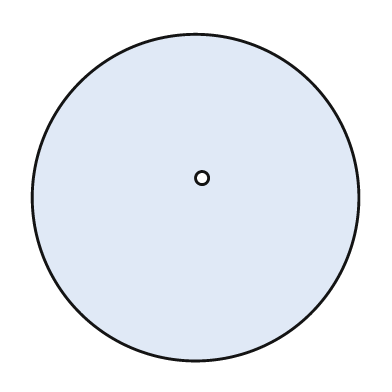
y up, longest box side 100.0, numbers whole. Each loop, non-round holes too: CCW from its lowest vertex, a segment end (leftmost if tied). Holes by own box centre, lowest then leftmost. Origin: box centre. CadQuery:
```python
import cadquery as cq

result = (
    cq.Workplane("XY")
    .moveTo(0.0, 0.0)
    .circle(50.0)
    .moveTo(2.0, 6.0)
    .circle(2.0)
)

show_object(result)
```